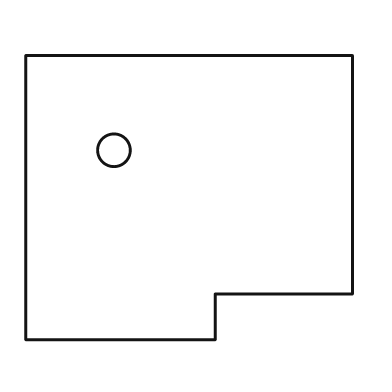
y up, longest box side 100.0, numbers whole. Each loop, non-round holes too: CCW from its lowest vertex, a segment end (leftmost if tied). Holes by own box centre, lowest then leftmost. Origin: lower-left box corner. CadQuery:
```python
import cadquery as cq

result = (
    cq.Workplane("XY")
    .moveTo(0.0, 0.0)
    .lineTo(58.0, 0.0)
    .lineTo(58.0, 14.0)
    .lineTo(100.0, 14.0)
    .lineTo(100.0, 87.0)
    .lineTo(0.0, 87.0)
    .close()
    .moveTo(27.0, 58.0)
    .circle(5.0)
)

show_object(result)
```